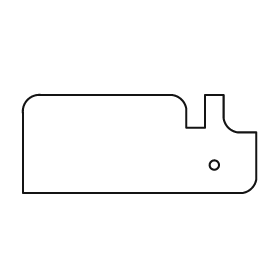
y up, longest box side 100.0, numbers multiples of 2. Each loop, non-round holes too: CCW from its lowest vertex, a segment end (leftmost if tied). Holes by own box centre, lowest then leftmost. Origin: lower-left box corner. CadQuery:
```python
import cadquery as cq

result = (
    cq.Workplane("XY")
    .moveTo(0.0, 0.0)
    .lineTo(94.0, 0.0)
    .threePointArc((98.0, 2.0), (100.0, 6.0))
    .lineTo(100.0, 26.0)
    .lineTo(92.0, 26.0)
    .threePointArc((88.0, 28.0), (86.0, 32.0))
    .lineTo(86.0, 42.0)
    .lineTo(78.0, 42.0)
    .lineTo(78.0, 28.0)
    .lineTo(70.0, 28.0)
    .lineTo(70.0, 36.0)
    .threePointArc((68.0, 40.0), (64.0, 42.0))
    .lineTo(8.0, 42.0)
    .threePointArc((2.0, 40.0), (0.0, 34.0))
    .close()
    .moveTo(82.0, 12.0)
    .circle(2.0)
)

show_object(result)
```